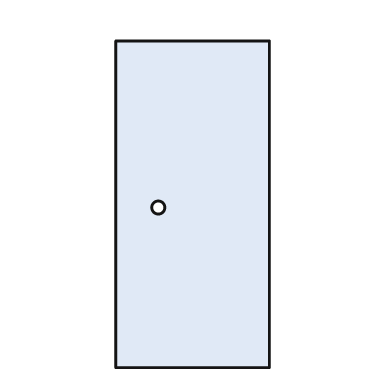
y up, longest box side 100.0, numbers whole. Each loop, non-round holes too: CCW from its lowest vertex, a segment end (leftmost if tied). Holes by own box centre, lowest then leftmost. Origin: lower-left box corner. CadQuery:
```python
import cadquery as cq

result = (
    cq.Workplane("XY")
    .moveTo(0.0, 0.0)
    .lineTo(47.0, 0.0)
    .lineTo(47.0, 100.0)
    .lineTo(0.0, 100.0)
    .close()
    .moveTo(13.0, 49.0)
    .circle(2.0)
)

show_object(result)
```